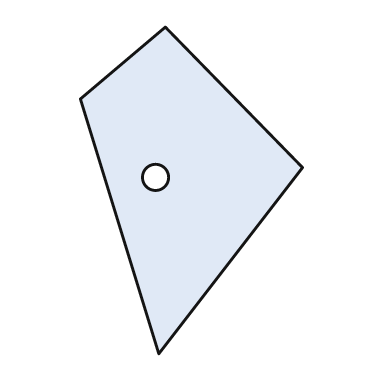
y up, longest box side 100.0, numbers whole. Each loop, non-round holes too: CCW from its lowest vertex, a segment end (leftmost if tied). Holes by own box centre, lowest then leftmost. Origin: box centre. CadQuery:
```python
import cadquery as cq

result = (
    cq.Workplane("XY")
    .moveTo(-10.0, -50.0)
    .lineTo(34.0, 7.0)
    .lineTo(-8.0, 50.0)
    .lineTo(-34.0, 28.0)
    .close()
    .moveTo(-11.0, 4.0)
    .circle(4.0)
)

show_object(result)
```